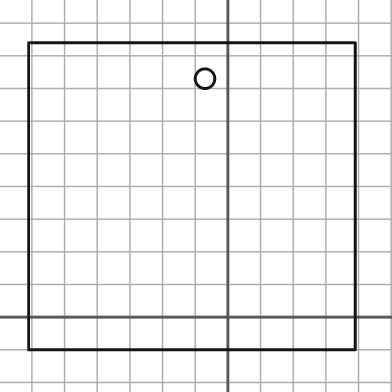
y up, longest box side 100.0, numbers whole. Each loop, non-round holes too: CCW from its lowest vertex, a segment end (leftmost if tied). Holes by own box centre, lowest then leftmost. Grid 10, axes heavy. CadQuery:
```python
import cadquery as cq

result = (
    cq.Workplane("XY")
    .moveTo(-61.0, -10.0)
    .lineTo(39.0, -10.0)
    .lineTo(39.0, 84.0)
    .lineTo(-61.0, 84.0)
    .close()
    .moveTo(-7.0, 73.0)
    .circle(3.0)
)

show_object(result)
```